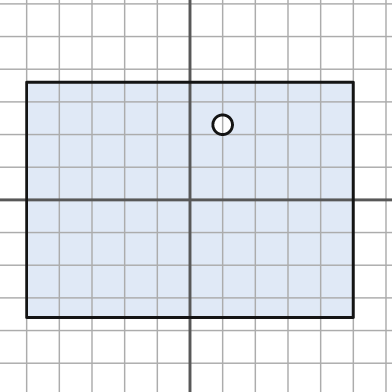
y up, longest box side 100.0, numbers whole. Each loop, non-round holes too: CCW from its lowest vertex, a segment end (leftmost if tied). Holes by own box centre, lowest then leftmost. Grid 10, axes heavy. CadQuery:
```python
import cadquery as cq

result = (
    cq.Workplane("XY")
    .moveTo(-50.0, -36.0)
    .lineTo(50.0, -36.0)
    .lineTo(50.0, 36.0)
    .lineTo(-50.0, 36.0)
    .close()
    .moveTo(10.0, 23.0)
    .circle(3.0)
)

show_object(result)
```